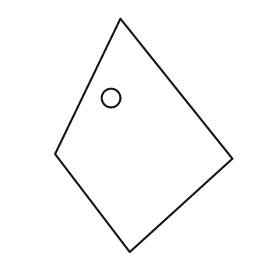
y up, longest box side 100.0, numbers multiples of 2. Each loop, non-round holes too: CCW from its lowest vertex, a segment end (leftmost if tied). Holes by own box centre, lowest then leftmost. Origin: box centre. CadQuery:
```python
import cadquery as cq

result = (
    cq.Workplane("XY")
    .moveTo(-6.0, -50.0)
    .lineTo(38.0, -10.0)
    .lineTo(-10.0, 50.0)
    .lineTo(-38.0, -8.0)
    .close()
    .moveTo(-14.0, 16.0)
    .circle(4.0)
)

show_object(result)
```